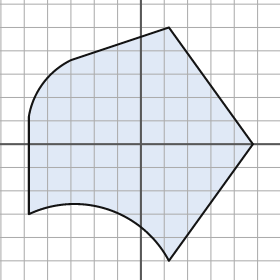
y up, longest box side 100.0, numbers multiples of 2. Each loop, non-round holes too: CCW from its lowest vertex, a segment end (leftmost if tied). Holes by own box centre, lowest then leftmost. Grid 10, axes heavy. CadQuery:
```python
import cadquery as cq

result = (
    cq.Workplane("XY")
    .moveTo(12.0, -50.0)
    .lineTo(48.0, 0.0)
    .lineTo(12.0, 50.0)
    .lineTo(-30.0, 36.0)
    .threePointArc((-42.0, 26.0), (-48.0, 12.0))
    .lineTo(-48.0, -30.0)
    .threePointArc((-14.0, -28.0), (12.0, -50.0))
    .close()
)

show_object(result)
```